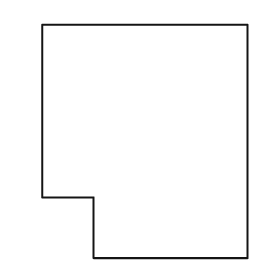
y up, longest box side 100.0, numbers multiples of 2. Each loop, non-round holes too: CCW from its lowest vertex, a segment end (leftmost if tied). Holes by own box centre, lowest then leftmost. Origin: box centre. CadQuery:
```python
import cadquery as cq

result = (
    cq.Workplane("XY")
    .moveTo(-22.0, -50.0)
    .lineTo(44.0, -50.0)
    .lineTo(44.0, 50.0)
    .lineTo(-44.0, 50.0)
    .lineTo(-44.0, -24.0)
    .lineTo(-22.0, -24.0)
    .close()
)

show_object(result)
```